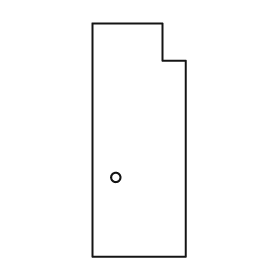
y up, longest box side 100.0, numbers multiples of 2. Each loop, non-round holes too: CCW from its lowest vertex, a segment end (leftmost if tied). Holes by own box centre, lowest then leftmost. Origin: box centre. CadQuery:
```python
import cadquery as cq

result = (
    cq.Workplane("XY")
    .moveTo(-20.0, -50.0)
    .lineTo(20.0, -50.0)
    .lineTo(20.0, 34.0)
    .lineTo(10.0, 34.0)
    .lineTo(10.0, 50.0)
    .lineTo(-20.0, 50.0)
    .close()
    .moveTo(-10.0, -16.0)
    .circle(2.0)
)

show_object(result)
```